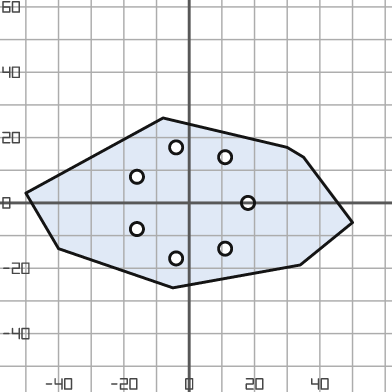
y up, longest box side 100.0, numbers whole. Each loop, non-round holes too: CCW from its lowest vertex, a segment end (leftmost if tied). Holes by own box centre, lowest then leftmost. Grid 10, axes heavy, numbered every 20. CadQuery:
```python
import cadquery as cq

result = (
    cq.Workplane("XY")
    .moveTo(-5.0, -26.0)
    .lineTo(34.0, -19.0)
    .lineTo(50.0, -6.0)
    .lineTo(35.0, 14.0)
    .lineTo(30.0, 17.0)
    .lineTo(-8.0, 26.0)
    .lineTo(-50.0, 3.0)
    .lineTo(-40.0, -14.0)
    .close()
    .moveTo(-4.0, -17.0)
    .circle(2.0)
    .moveTo(11.0, -14.0)
    .circle(2.0)
    .moveTo(-16.0, -8.0)
    .circle(2.0)
    .moveTo(18.0, 0.0)
    .circle(2.0)
    .moveTo(-16.0, 8.0)
    .circle(2.0)
    .moveTo(11.0, 14.0)
    .circle(2.0)
    .moveTo(-4.0, 17.0)
    .circle(2.0)
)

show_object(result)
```